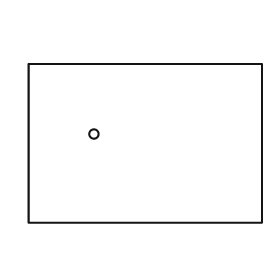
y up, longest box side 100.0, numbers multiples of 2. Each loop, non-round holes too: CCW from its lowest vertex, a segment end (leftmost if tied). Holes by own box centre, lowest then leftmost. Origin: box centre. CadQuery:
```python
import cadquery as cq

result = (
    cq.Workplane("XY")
    .moveTo(-50.0, -34.0)
    .lineTo(50.0, -34.0)
    .lineTo(50.0, 34.0)
    .lineTo(-50.0, 34.0)
    .close()
    .moveTo(-22.0, 4.0)
    .circle(2.0)
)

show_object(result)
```